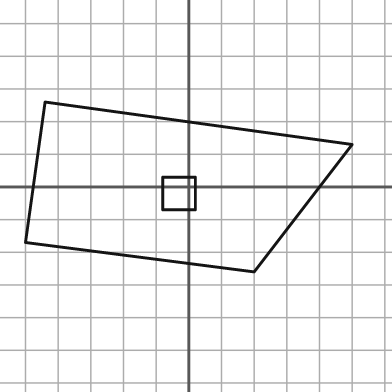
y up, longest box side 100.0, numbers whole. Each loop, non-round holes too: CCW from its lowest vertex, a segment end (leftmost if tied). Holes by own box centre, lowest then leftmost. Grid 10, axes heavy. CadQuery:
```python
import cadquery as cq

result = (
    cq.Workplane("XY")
    .moveTo(20.0, -26.0)
    .lineTo(50.0, 13.0)
    .lineTo(-44.0, 26.0)
    .lineTo(-50.0, -17.0)
    .close()
    .moveTo(-8.0, -7.0)
    .lineTo(2.0, -7.0)
    .lineTo(2.0, 3.0)
    .lineTo(-8.0, 3.0)
    .close()
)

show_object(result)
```